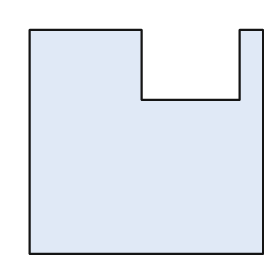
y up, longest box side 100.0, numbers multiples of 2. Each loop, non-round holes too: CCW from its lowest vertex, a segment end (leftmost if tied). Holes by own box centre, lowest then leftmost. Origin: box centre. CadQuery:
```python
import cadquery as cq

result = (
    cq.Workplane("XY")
    .moveTo(-50.0, -48.0)
    .lineTo(50.0, -48.0)
    .lineTo(50.0, 48.0)
    .lineTo(40.0, 48.0)
    .lineTo(40.0, 18.0)
    .lineTo(-2.0, 18.0)
    .lineTo(-2.0, 48.0)
    .lineTo(-50.0, 48.0)
    .close()
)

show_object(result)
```